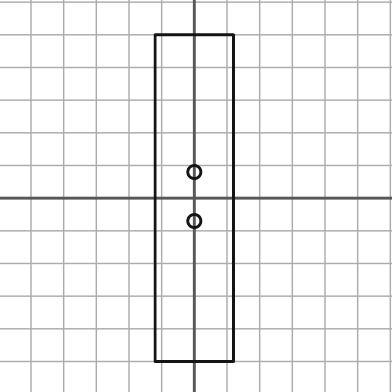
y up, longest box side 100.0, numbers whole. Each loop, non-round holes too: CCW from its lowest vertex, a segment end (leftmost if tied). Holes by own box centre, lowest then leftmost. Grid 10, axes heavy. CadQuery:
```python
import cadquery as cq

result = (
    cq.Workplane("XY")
    .moveTo(-12.0, -50.0)
    .lineTo(12.0, -50.0)
    .lineTo(12.0, 50.0)
    .lineTo(-12.0, 50.0)
    .close()
    .moveTo(0.0, -7.0)
    .circle(2.0)
    .moveTo(0.0, 8.0)
    .circle(2.0)
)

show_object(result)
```